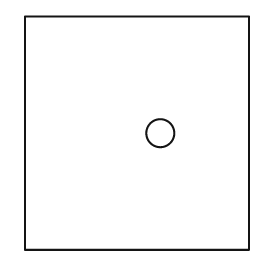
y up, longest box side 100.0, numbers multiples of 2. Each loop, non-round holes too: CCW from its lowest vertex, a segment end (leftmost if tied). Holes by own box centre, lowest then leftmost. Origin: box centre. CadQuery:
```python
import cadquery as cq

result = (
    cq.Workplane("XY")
    .moveTo(-48.0, -50.0)
    .lineTo(48.0, -50.0)
    .lineTo(48.0, 50.0)
    .lineTo(-48.0, 50.0)
    .close()
    .moveTo(10.0, 0.0)
    .circle(6.0)
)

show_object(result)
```